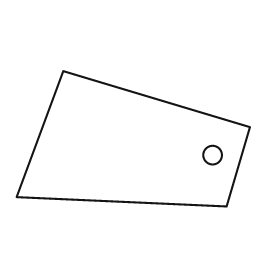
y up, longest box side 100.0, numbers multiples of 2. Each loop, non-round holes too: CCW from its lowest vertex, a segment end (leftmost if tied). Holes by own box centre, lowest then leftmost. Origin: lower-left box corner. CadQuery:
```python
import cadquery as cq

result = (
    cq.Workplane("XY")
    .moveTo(90.0, 0.0)
    .lineTo(100.0, 34.0)
    .lineTo(20.0, 58.0)
    .lineTo(0.0, 4.0)
    .close()
    .moveTo(84.0, 22.0)
    .circle(4.0)
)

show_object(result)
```